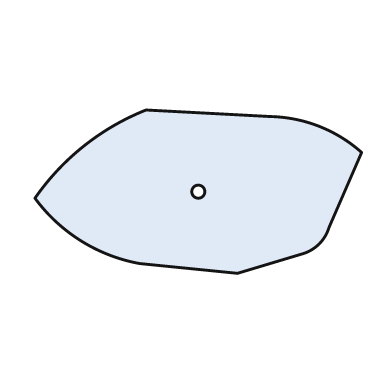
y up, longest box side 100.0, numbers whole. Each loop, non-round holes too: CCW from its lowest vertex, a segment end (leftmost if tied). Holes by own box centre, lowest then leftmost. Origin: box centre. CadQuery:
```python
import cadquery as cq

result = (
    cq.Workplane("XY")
    .moveTo(12.0, -25.0)
    .lineTo(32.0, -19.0)
    .threePointArc((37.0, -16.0), (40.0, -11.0))
    .lineTo(50.0, 12.0)
    .threePointArc((37.0, 20.0), (22.0, 23.0))
    .lineTo(-16.0, 25.0)
    .threePointArc((-35.0, 14.0), (-50.0, -2.0))
    .threePointArc((-36.0, -15.0), (-18.0, -22.0))
    .close()
    .moveTo(0.0, 0.0)
    .circle(2.0)
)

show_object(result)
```